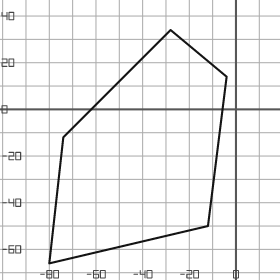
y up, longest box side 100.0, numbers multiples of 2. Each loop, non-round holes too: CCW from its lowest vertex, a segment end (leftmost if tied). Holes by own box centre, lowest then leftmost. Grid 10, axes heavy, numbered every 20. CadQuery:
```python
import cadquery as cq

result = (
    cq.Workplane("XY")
    .moveTo(-80.0, -66.0)
    .lineTo(-12.0, -50.0)
    .lineTo(-4.0, 14.0)
    .lineTo(-28.0, 34.0)
    .lineTo(-74.0, -12.0)
    .close()
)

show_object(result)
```